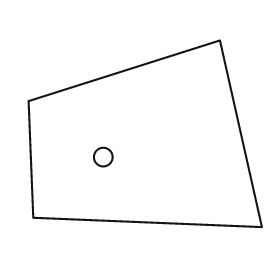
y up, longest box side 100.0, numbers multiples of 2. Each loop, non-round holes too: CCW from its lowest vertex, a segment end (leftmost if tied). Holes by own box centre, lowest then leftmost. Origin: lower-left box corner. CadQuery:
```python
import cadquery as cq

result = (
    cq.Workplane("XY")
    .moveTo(100.0, 0.0)
    .lineTo(82.0, 80.0)
    .lineTo(0.0, 54.0)
    .lineTo(2.0, 4.0)
    .close()
    .moveTo(32.0, 30.0)
    .circle(4.0)
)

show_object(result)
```